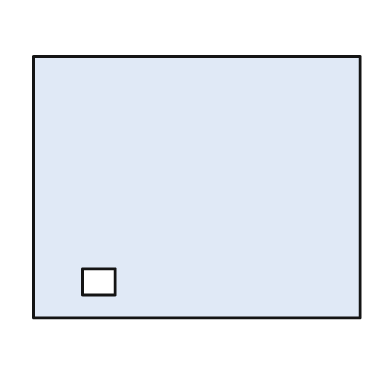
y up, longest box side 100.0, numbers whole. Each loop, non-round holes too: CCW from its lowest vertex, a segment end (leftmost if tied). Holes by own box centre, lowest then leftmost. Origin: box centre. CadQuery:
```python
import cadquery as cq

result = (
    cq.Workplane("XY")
    .moveTo(-50.0, -40.0)
    .lineTo(50.0, -40.0)
    .lineTo(50.0, 40.0)
    .lineTo(-50.0, 40.0)
    .close()
    .moveTo(-35.0, -33.0)
    .lineTo(-25.0, -33.0)
    .lineTo(-25.0, -25.0)
    .lineTo(-35.0, -25.0)
    .close()
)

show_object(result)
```